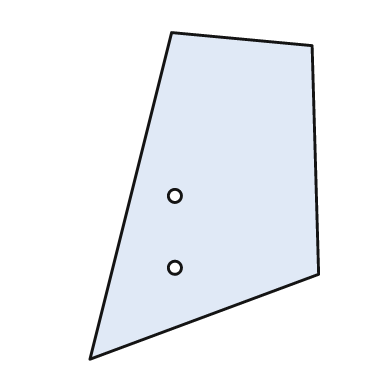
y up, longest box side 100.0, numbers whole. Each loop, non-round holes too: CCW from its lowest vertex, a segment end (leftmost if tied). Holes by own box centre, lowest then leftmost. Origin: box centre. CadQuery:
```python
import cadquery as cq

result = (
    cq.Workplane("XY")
    .moveTo(-35.0, -50.0)
    .lineTo(35.0, -24.0)
    .lineTo(33.0, 46.0)
    .lineTo(-10.0, 50.0)
    .close()
    .moveTo(-9.0, -22.0)
    .circle(2.0)
    .moveTo(-9.0, 0.0)
    .circle(2.0)
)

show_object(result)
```